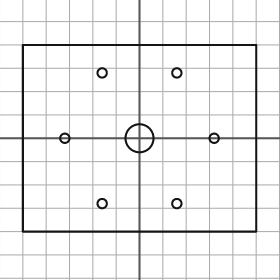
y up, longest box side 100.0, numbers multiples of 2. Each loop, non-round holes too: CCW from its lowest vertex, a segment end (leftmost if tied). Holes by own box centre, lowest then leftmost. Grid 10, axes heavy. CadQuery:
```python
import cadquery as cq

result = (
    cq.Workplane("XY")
    .moveTo(-50.0, -40.0)
    .lineTo(50.0, -40.0)
    .lineTo(50.0, 40.0)
    .lineTo(-50.0, 40.0)
    .close()
    .moveTo(-16.0, -28.0)
    .circle(2.0)
    .moveTo(16.0, -28.0)
    .circle(2.0)
    .moveTo(-32.0, 0.0)
    .circle(2.0)
    .moveTo(0.0, 0.0)
    .circle(6.0)
    .moveTo(32.0, 0.0)
    .circle(2.0)
    .moveTo(-16.0, 28.0)
    .circle(2.0)
    .moveTo(16.0, 28.0)
    .circle(2.0)
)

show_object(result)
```